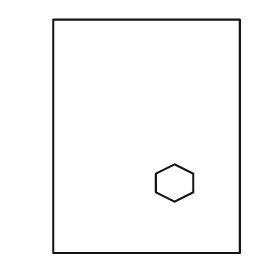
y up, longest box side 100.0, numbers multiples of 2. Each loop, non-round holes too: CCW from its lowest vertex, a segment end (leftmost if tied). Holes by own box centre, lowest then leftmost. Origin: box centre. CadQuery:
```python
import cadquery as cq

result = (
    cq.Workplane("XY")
    .moveTo(-40.0, -50.0)
    .lineTo(40.0, -50.0)
    .lineTo(40.0, 50.0)
    .lineTo(-40.0, 50.0)
    .close()
    .moveTo(12.0, -28.0)
    .lineTo(20.0, -24.0)
    .lineTo(20.0, -16.0)
    .lineTo(12.0, -12.0)
    .lineTo(4.0, -16.0)
    .lineTo(4.0, -24.0)
    .close()
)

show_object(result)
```